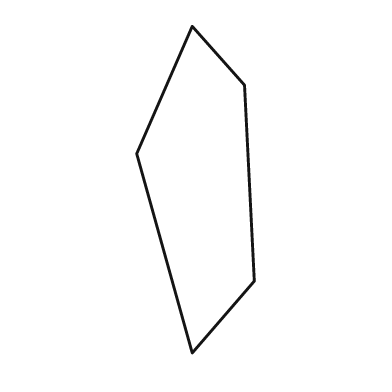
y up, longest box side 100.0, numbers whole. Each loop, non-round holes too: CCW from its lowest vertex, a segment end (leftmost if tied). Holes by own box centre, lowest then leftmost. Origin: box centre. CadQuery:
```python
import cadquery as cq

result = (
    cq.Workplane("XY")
    .moveTo(-1.0, -50.0)
    .lineTo(18.0, -28.0)
    .lineTo(15.0, 32.0)
    .lineTo(-1.0, 50.0)
    .lineTo(-18.0, 11.0)
    .close()
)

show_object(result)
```